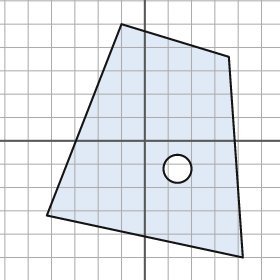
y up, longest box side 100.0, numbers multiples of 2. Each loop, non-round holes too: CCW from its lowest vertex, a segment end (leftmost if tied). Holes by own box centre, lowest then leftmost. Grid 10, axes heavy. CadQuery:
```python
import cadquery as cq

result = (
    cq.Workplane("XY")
    .moveTo(42.0, -50.0)
    .lineTo(36.0, 36.0)
    .lineTo(-10.0, 50.0)
    .lineTo(-42.0, -32.0)
    .close()
    .moveTo(14.0, -12.0)
    .circle(6.0)
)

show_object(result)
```